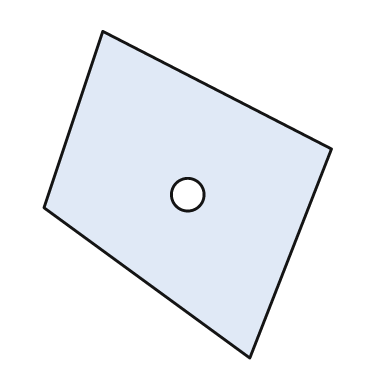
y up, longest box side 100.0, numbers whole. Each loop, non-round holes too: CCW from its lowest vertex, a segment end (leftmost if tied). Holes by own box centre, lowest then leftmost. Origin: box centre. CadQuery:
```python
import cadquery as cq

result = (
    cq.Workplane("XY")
    .moveTo(19.0, -50.0)
    .lineTo(44.0, 14.0)
    .lineTo(-26.0, 50.0)
    .lineTo(-44.0, -4.0)
    .close()
    .moveTo(0.0, 0.0)
    .circle(5.0)
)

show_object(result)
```